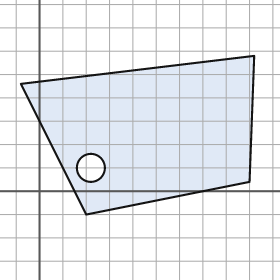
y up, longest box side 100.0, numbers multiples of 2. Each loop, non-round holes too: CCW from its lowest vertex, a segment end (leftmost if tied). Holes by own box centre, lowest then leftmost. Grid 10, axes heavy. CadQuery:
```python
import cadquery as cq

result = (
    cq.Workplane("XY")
    .moveTo(20.0, -10.0)
    .lineTo(90.0, 4.0)
    .lineTo(92.0, 58.0)
    .lineTo(-8.0, 46.0)
    .close()
    .moveTo(22.0, 10.0)
    .circle(6.0)
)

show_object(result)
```